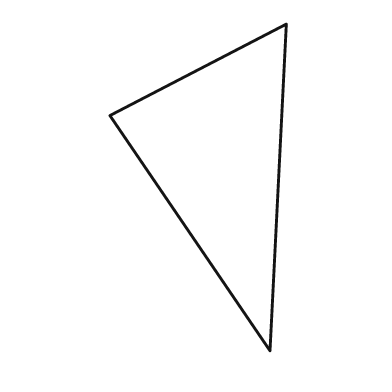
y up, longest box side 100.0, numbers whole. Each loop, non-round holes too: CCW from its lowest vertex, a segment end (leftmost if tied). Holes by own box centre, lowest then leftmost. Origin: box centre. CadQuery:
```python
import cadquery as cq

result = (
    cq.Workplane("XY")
    .moveTo(22.0, -50.0)
    .lineTo(27.0, 50.0)
    .lineTo(-27.0, 22.0)
    .close()
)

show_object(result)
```